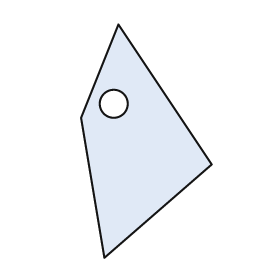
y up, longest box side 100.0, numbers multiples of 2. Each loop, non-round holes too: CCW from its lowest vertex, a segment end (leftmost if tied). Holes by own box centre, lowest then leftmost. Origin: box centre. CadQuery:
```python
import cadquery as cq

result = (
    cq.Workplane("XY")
    .moveTo(-18.0, -50.0)
    .lineTo(28.0, -10.0)
    .lineTo(-12.0, 50.0)
    .lineTo(-28.0, 10.0)
    .close()
    .moveTo(-14.0, 16.0)
    .circle(6.0)
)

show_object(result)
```